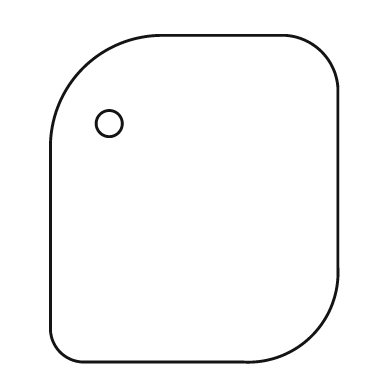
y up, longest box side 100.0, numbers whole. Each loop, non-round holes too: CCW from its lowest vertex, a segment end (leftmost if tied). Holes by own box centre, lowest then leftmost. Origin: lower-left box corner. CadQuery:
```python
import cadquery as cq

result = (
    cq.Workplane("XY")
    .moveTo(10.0, 0.0)
    .lineTo(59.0, 0.0)
    .threePointArc((80.0, 8.0), (88.0, 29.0))
    .lineTo(88.0, 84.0)
    .threePointArc((83.0, 95.0), (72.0, 100.0))
    .lineTo(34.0, 100.0)
    .threePointArc((10.0, 90.0), (0.0, 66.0))
    .lineTo(0.0, 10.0)
    .threePointArc((3.0, 3.0), (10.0, 0.0))
    .close()
    .moveTo(18.0, 73.0)
    .circle(4.0)
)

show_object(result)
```